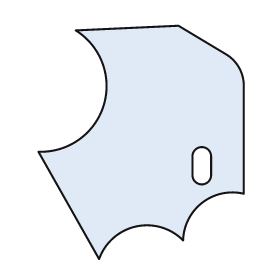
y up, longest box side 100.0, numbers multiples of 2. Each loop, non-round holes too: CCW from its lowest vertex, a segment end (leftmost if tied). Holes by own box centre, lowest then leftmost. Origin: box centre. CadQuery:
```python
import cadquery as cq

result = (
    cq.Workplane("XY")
    .moveTo(-18.0, -50.0)
    .threePointArc((-2.0, -36.0), (18.0, -42.0))
    .threePointArc((26.0, -26.0), (44.0, -22.0))
    .lineTo(44.0, 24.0)
    .threePointArc((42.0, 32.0), (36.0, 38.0))
    .lineTo(16.0, 50.0)
    .lineTo(-28.0, 48.0)
    .threePointArc((-16.0, 16.0), (-44.0, -4.0))
    .close()
    .moveTo(22.0, -14.0)
    .threePointArc((26.0, -18.0), (30.0, -14.0))
    .lineTo(30.0, -6.0)
    .threePointArc((26.0, -2.0), (22.0, -6.0))
    .close()
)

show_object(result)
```